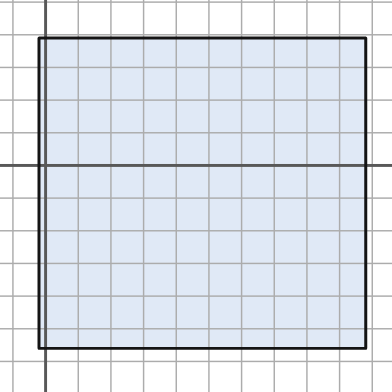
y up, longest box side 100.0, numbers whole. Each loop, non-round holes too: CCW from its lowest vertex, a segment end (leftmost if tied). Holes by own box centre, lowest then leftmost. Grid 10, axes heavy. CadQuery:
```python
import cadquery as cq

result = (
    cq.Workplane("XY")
    .moveTo(-2.0, -56.0)
    .lineTo(98.0, -56.0)
    .lineTo(98.0, 39.0)
    .lineTo(-2.0, 39.0)
    .close()
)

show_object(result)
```